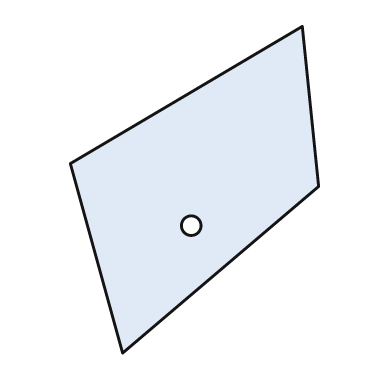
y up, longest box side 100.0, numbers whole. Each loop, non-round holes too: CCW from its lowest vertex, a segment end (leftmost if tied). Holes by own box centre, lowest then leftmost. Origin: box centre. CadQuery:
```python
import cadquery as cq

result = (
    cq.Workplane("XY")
    .moveTo(-22.0, -50.0)
    .lineTo(38.0, 1.0)
    .lineTo(33.0, 50.0)
    .lineTo(-38.0, 8.0)
    .close()
    .moveTo(-1.0, -11.0)
    .circle(3.0)
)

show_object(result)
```